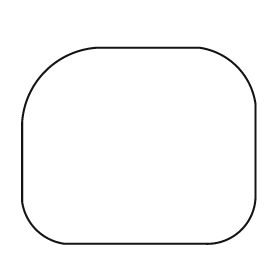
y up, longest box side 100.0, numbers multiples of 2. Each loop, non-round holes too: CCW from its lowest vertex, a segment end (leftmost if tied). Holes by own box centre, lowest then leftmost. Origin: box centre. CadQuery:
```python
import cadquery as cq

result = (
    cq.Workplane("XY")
    .moveTo(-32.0, -42.0)
    .lineTo(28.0, -42.0)
    .threePointArc((44.0, -36.0), (50.0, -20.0))
    .lineTo(50.0, 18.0)
    .threePointArc((42.0, 34.0), (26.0, 42.0))
    .lineTo(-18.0, 42.0)
    .threePointArc((-40.0, 32.0), (-50.0, 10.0))
    .lineTo(-50.0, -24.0)
    .threePointArc((-44.0, -36.0), (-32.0, -42.0))
    .close()
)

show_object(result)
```